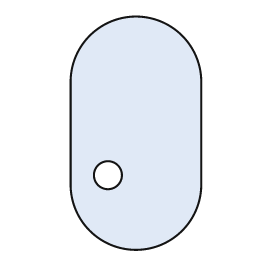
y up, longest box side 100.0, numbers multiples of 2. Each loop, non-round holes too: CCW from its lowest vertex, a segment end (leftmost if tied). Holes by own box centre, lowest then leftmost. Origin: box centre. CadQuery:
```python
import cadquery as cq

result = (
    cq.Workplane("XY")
    .moveTo(-28.0, -22.0)
    .threePointArc((0.0, -50.0), (28.0, -22.0))
    .lineTo(28.0, 22.0)
    .threePointArc((0.0, 50.0), (-28.0, 22.0))
    .close()
    .moveTo(-12.0, -18.0)
    .circle(6.0)
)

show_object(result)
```